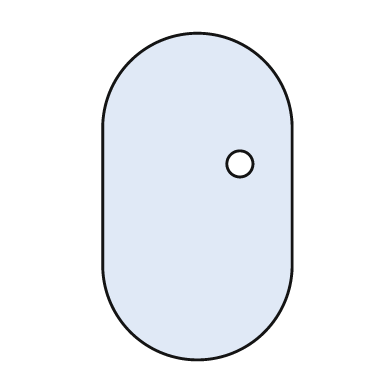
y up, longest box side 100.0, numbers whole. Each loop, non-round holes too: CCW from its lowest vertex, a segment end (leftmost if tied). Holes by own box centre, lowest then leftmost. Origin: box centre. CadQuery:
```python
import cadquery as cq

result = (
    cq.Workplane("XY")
    .moveTo(-29.0, -21.0)
    .threePointArc((0.0, -50.0), (29.0, -21.0))
    .lineTo(29.0, 21.0)
    .threePointArc((0.0, 50.0), (-29.0, 21.0))
    .close()
    .moveTo(13.0, 10.0)
    .circle(4.0)
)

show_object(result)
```